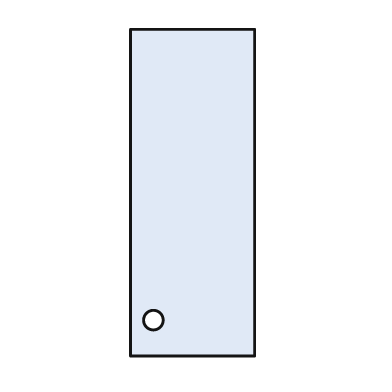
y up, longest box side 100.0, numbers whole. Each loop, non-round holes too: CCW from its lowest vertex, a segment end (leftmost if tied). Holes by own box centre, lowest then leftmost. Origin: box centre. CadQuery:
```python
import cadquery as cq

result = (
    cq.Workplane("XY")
    .moveTo(-19.0, -50.0)
    .lineTo(19.0, -50.0)
    .lineTo(19.0, 50.0)
    .lineTo(-19.0, 50.0)
    .close()
    .moveTo(-12.0, -39.0)
    .circle(3.0)
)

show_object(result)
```